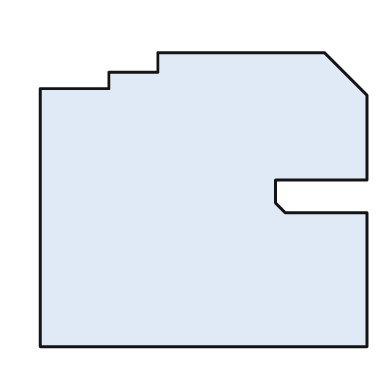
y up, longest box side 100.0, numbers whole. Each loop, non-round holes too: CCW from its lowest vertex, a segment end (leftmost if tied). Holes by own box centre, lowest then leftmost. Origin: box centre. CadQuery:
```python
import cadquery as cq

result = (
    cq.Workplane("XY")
    .moveTo(-50.0, -45.0)
    .lineTo(50.0, -45.0)
    .lineTo(50.0, -4.0)
    .lineTo(25.0, -4.0)
    .lineTo(22.0, -1.0)
    .lineTo(22.0, 6.0)
    .lineTo(50.0, 6.0)
    .lineTo(50.0, 32.0)
    .lineTo(37.0, 45.0)
    .lineTo(-14.0, 45.0)
    .lineTo(-14.0, 39.0)
    .lineTo(-29.0, 39.0)
    .lineTo(-29.0, 34.0)
    .lineTo(-50.0, 34.0)
    .close()
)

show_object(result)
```